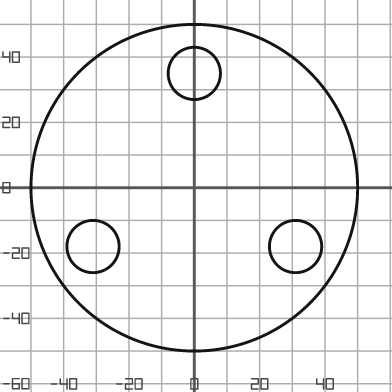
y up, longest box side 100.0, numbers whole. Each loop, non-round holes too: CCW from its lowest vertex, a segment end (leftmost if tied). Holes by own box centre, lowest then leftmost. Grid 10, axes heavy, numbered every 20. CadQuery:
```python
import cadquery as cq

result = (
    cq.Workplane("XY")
    .moveTo(0.0, 0.0)
    .circle(50.0)
    .moveTo(-31.0, -18.0)
    .circle(8.0)
    .moveTo(31.0, -18.0)
    .circle(8.0)
    .moveTo(0.0, 35.0)
    .circle(8.0)
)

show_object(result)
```